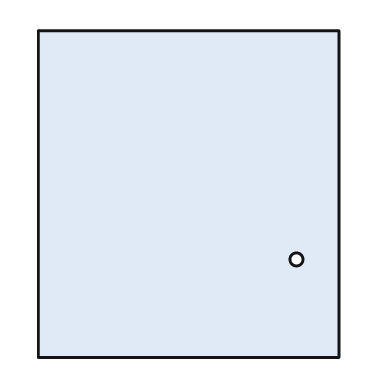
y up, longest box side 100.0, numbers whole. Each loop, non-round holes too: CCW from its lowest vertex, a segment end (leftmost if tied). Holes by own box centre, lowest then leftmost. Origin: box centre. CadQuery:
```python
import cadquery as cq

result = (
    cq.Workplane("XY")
    .moveTo(-46.0, -50.0)
    .lineTo(46.0, -50.0)
    .lineTo(46.0, 50.0)
    .lineTo(-46.0, 50.0)
    .close()
    .moveTo(33.0, -20.0)
    .circle(2.0)
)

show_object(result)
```